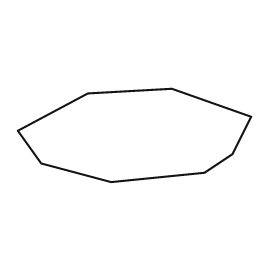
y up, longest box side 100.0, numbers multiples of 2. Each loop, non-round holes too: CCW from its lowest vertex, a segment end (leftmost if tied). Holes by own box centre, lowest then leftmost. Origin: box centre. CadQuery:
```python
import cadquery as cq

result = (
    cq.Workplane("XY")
    .moveTo(-10.0, -20.0)
    .lineTo(30.0, -16.0)
    .lineTo(42.0, -8.0)
    .lineTo(50.0, 8.0)
    .lineTo(16.0, 20.0)
    .lineTo(-20.0, 18.0)
    .lineTo(-50.0, 2.0)
    .lineTo(-40.0, -12.0)
    .close()
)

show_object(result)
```